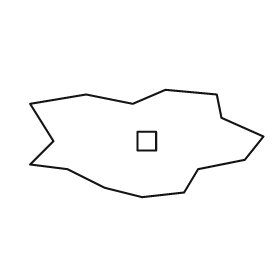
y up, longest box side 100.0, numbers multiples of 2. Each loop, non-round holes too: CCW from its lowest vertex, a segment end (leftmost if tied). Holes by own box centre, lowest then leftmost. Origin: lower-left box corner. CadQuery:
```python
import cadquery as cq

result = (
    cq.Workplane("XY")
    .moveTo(48.0, 0.0)
    .lineTo(66.0, 2.0)
    .lineTo(72.0, 12.0)
    .lineTo(92.0, 16.0)
    .lineTo(100.0, 26.0)
    .lineTo(82.0, 34.0)
    .lineTo(80.0, 44.0)
    .lineTo(58.0, 46.0)
    .lineTo(44.0, 40.0)
    .lineTo(24.0, 44.0)
    .lineTo(0.0, 40.0)
    .lineTo(10.0, 24.0)
    .lineTo(0.0, 14.0)
    .lineTo(16.0, 12.0)
    .lineTo(32.0, 4.0)
    .close()
    .moveTo(46.0, 20.0)
    .lineTo(54.0, 20.0)
    .lineTo(54.0, 28.0)
    .lineTo(46.0, 28.0)
    .close()
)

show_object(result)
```